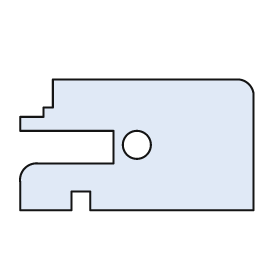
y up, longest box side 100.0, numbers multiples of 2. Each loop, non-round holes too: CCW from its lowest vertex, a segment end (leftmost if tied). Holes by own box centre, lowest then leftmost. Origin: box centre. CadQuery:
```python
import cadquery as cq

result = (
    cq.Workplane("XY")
    .moveTo(-50.0, -28.0)
    .lineTo(-28.0, -28.0)
    .lineTo(-28.0, -20.0)
    .lineTo(-20.0, -20.0)
    .lineTo(-20.0, -28.0)
    .lineTo(50.0, -28.0)
    .lineTo(50.0, 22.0)
    .threePointArc((48.0, 26.0), (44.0, 28.0))
    .lineTo(-36.0, 28.0)
    .lineTo(-36.0, 16.0)
    .lineTo(-40.0, 16.0)
    .lineTo(-40.0, 12.0)
    .lineTo(-50.0, 12.0)
    .lineTo(-50.0, 6.0)
    .lineTo(-10.0, 6.0)
    .lineTo(-10.0, -8.0)
    .lineTo(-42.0, -8.0)
    .threePointArc((-48.0, -10.0), (-50.0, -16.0))
    .close()
    .moveTo(0.0, 0.0)
    .circle(6.0)
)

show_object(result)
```